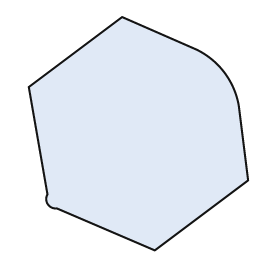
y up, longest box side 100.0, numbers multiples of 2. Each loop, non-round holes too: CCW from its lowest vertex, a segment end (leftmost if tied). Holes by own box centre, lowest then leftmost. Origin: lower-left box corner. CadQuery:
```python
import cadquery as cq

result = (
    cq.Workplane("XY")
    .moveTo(54.0, 0.0)
    .lineTo(94.0, 30.0)
    .lineTo(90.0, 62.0)
    .threePointArc((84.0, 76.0), (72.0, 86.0))
    .lineTo(40.0, 100.0)
    .lineTo(0.0, 70.0)
    .lineTo(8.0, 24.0)
    .threePointArc((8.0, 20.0), (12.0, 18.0))
    .close()
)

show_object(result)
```